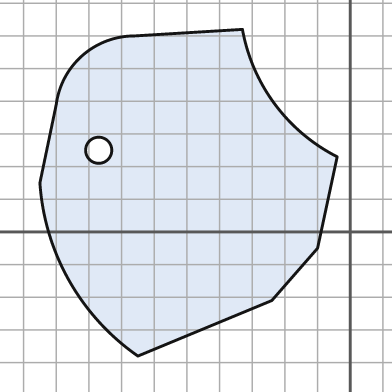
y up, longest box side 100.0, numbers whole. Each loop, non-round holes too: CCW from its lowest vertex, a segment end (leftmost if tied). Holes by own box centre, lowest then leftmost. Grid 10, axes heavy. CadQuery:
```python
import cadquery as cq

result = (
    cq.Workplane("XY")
    .moveTo(-65.0, -38.0)
    .lineTo(-24.0, -21.0)
    .lineTo(-10.0, -5.0)
    .lineTo(-4.0, 23.0)
    .threePointArc((-23.0, 39.0), (-33.0, 62.0))
    .lineTo(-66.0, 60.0)
    .threePointArc((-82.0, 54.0), (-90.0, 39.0))
    .lineTo(-95.0, 15.0)
    .threePointArc((-86.0, -15.0), (-65.0, -38.0))
    .close()
    .moveTo(-77.0, 25.0)
    .circle(4.0)
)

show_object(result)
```